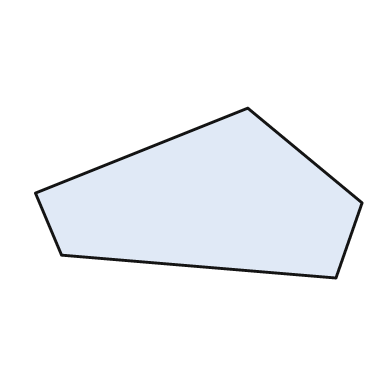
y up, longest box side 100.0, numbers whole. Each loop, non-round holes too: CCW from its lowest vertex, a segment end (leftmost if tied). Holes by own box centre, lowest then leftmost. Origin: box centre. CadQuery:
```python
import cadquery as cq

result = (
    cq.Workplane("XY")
    .moveTo(42.0, -26.0)
    .lineTo(50.0, -3.0)
    .lineTo(15.0, 26.0)
    .lineTo(-50.0, 0.0)
    .lineTo(-42.0, -19.0)
    .close()
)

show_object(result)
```